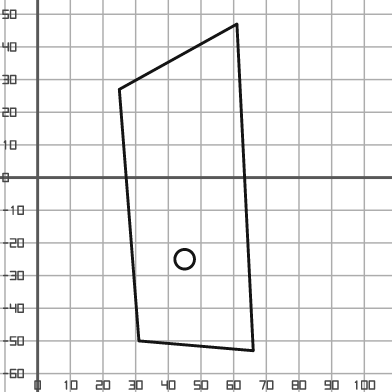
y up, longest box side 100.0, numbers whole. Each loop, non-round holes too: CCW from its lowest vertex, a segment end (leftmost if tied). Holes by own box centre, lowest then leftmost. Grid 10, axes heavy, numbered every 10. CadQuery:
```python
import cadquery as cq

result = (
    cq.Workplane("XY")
    .moveTo(66.0, -53.0)
    .lineTo(61.0, 47.0)
    .lineTo(25.0, 27.0)
    .lineTo(31.0, -50.0)
    .close()
    .moveTo(45.0, -25.0)
    .circle(3.0)
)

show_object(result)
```